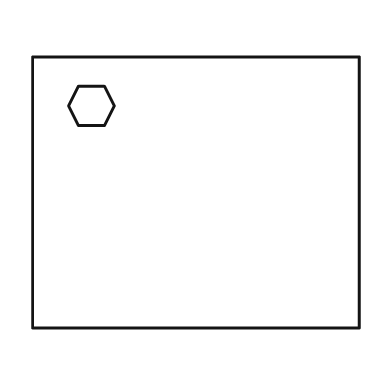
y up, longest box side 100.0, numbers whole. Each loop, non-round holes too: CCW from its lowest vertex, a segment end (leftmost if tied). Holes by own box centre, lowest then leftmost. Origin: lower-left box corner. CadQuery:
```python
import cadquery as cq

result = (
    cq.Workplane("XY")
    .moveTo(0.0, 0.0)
    .lineTo(100.0, 0.0)
    .lineTo(100.0, 83.0)
    .lineTo(0.0, 83.0)
    .close()
    .moveTo(14.0, 62.0)
    .lineTo(22.0, 62.0)
    .lineTo(25.0, 68.0)
    .lineTo(22.0, 74.0)
    .lineTo(14.0, 74.0)
    .lineTo(11.0, 68.0)
    .close()
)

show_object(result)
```